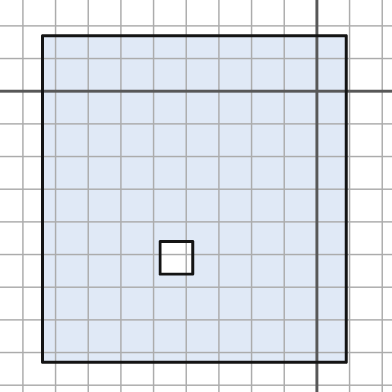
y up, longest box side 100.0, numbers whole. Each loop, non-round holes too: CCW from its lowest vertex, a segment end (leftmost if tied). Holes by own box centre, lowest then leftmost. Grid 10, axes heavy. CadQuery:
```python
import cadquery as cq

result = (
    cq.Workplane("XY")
    .moveTo(-84.0, -83.0)
    .lineTo(9.0, -83.0)
    .lineTo(9.0, 17.0)
    .lineTo(-84.0, 17.0)
    .close()
    .moveTo(-48.0, -56.0)
    .lineTo(-38.0, -56.0)
    .lineTo(-38.0, -46.0)
    .lineTo(-48.0, -46.0)
    .close()
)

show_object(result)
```